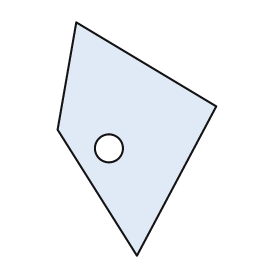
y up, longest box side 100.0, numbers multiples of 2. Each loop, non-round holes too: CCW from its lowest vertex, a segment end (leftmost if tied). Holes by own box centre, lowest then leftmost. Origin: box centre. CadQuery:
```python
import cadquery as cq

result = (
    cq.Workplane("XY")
    .moveTo(0.0, -50.0)
    .lineTo(34.0, 14.0)
    .lineTo(-26.0, 50.0)
    .lineTo(-34.0, 4.0)
    .close()
    .moveTo(-12.0, -4.0)
    .circle(6.0)
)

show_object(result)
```